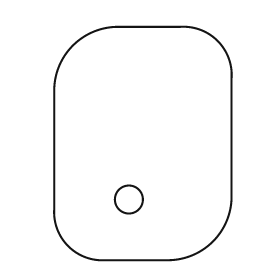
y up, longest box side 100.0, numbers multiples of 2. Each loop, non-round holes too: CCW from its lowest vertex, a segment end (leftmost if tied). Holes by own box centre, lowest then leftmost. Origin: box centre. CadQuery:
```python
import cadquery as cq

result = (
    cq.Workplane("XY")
    .moveTo(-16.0, -50.0)
    .lineTo(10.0, -50.0)
    .threePointArc((30.0, -42.0), (38.0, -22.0))
    .lineTo(38.0, 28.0)
    .threePointArc((32.0, 44.0), (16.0, 50.0))
    .lineTo(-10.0, 50.0)
    .threePointArc((-30.0, 42.0), (-38.0, 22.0))
    .lineTo(-38.0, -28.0)
    .threePointArc((-32.0, -44.0), (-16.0, -50.0))
    .close()
    .moveTo(-6.0, -24.0)
    .circle(6.0)
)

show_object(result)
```